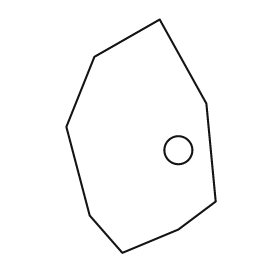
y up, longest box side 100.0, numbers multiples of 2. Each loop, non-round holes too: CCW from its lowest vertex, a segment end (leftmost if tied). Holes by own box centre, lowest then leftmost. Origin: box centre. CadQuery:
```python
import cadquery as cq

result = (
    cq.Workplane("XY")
    .moveTo(-8.0, -50.0)
    .lineTo(16.0, -40.0)
    .lineTo(32.0, -28.0)
    .lineTo(28.0, 14.0)
    .lineTo(8.0, 50.0)
    .lineTo(-20.0, 34.0)
    .lineTo(-32.0, 4.0)
    .lineTo(-22.0, -34.0)
    .close()
    .moveTo(16.0, -6.0)
    .circle(6.0)
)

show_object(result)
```